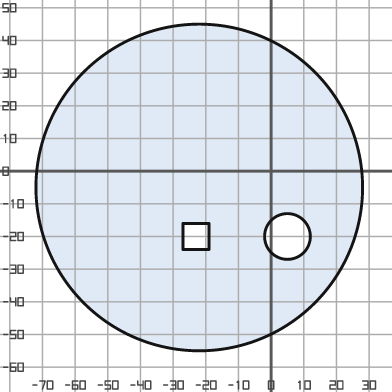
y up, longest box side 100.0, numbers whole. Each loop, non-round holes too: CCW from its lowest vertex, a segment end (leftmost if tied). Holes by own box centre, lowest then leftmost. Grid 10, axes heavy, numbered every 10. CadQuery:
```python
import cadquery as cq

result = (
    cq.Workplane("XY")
    .moveTo(-22.0, -5.0)
    .circle(50.0)
    .moveTo(-27.0, -24.0)
    .lineTo(-19.0, -24.0)
    .lineTo(-19.0, -16.0)
    .lineTo(-27.0, -16.0)
    .close()
    .moveTo(5.0, -20.0)
    .circle(7.0)
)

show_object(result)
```